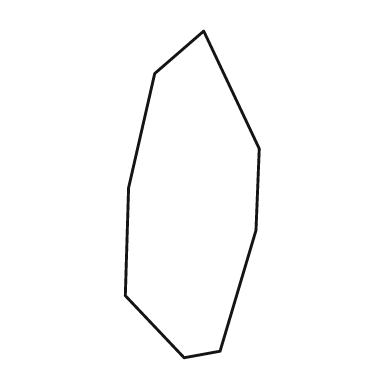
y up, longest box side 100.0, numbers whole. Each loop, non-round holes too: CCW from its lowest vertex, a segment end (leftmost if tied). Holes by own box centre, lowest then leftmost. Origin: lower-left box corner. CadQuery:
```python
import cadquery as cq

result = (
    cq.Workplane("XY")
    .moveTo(18.0, 0.0)
    .lineTo(29.0, 2.0)
    .lineTo(40.0, 39.0)
    .lineTo(41.0, 64.0)
    .lineTo(24.0, 100.0)
    .lineTo(9.0, 87.0)
    .lineTo(1.0, 52.0)
    .lineTo(0.0, 19.0)
    .close()
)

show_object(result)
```